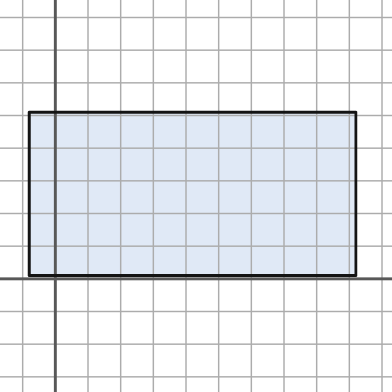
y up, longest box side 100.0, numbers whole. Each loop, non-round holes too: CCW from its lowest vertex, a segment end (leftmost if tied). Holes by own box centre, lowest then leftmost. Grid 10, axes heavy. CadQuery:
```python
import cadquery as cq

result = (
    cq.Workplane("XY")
    .moveTo(-8.0, 1.0)
    .lineTo(92.0, 1.0)
    .lineTo(92.0, 51.0)
    .lineTo(-8.0, 51.0)
    .close()
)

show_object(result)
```